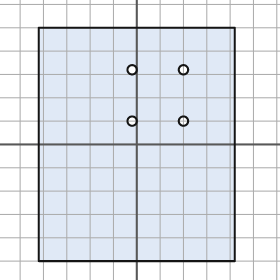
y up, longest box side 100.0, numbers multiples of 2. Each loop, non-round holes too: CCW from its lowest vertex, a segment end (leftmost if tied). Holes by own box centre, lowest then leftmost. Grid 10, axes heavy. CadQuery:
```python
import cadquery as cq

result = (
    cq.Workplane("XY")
    .moveTo(-42.0, -50.0)
    .lineTo(42.0, -50.0)
    .lineTo(42.0, 50.0)
    .lineTo(-42.0, 50.0)
    .close()
    .moveTo(-2.0, 10.0)
    .circle(2.0)
    .moveTo(20.0, 10.0)
    .circle(2.0)
    .moveTo(-2.0, 32.0)
    .circle(2.0)
    .moveTo(20.0, 32.0)
    .circle(2.0)
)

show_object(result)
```